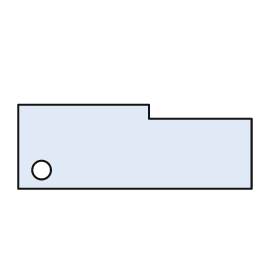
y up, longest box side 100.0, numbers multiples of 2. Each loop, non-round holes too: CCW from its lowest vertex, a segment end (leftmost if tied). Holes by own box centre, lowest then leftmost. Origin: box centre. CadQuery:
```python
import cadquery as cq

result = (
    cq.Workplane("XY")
    .moveTo(-50.0, -18.0)
    .lineTo(50.0, -18.0)
    .lineTo(50.0, 12.0)
    .lineTo(6.0, 12.0)
    .lineTo(6.0, 18.0)
    .lineTo(-50.0, 18.0)
    .close()
    .moveTo(-40.0, -10.0)
    .circle(4.0)
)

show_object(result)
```